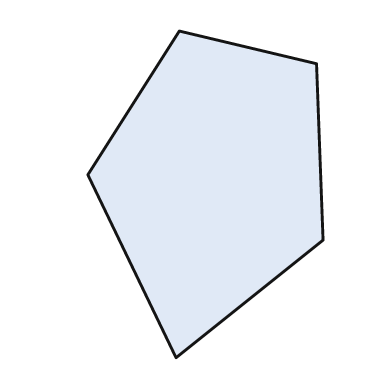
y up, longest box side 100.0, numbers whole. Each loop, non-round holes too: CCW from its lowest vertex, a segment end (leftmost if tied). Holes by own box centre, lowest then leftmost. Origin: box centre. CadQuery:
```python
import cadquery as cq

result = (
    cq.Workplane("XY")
    .moveTo(-9.0, -50.0)
    .lineTo(36.0, -14.0)
    .lineTo(34.0, 40.0)
    .lineTo(-8.0, 50.0)
    .lineTo(-36.0, 6.0)
    .close()
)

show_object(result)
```